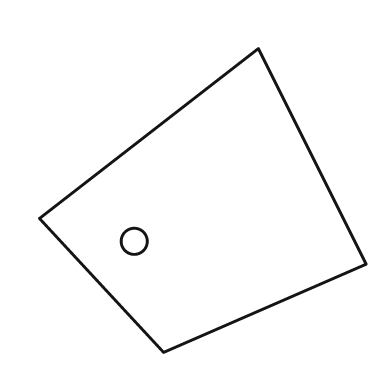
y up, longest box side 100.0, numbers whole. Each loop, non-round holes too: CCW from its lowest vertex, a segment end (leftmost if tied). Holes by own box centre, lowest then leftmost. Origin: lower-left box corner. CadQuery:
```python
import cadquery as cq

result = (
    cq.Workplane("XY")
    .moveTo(38.0, 0.0)
    .lineTo(100.0, 27.0)
    .lineTo(67.0, 93.0)
    .lineTo(0.0, 41.0)
    .close()
    .moveTo(29.0, 34.0)
    .circle(4.0)
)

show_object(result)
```